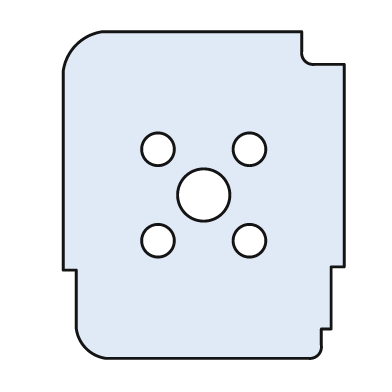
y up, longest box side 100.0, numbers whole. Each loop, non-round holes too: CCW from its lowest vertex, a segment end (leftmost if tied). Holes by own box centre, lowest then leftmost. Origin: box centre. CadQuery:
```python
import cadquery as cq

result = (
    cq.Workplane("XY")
    .moveTo(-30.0, -50.0)
    .lineTo(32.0, -50.0)
    .threePointArc((35.0, -49.0), (36.0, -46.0))
    .lineTo(36.0, -41.0)
    .lineTo(39.0, -41.0)
    .lineTo(39.0, -22.0)
    .lineTo(43.0, -22.0)
    .lineTo(43.0, 40.0)
    .lineTo(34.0, 40.0)
    .threePointArc((31.0, 41.0), (30.0, 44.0))
    .lineTo(30.0, 50.0)
    .lineTo(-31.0, 50.0)
    .threePointArc((-39.0, 46.0), (-43.0, 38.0))
    .lineTo(-43.0, -23.0)
    .lineTo(-39.0, -23.0)
    .lineTo(-39.0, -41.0)
    .threePointArc((-36.0, -47.0), (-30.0, -50.0))
    .close()
    .moveTo(-14.0, -14.0)
    .circle(5.0)
    .moveTo(14.0, -14.0)
    .circle(5.0)
    .moveTo(0.0, 0.0)
    .circle(8.0)
    .moveTo(-14.0, 14.0)
    .circle(5.0)
    .moveTo(14.0, 14.0)
    .circle(5.0)
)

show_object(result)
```